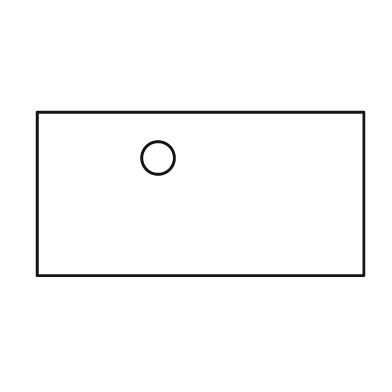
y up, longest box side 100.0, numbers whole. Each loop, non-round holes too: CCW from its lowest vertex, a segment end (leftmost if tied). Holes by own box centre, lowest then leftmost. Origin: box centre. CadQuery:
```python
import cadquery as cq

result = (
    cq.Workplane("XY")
    .moveTo(-50.0, -25.0)
    .lineTo(50.0, -25.0)
    .lineTo(50.0, 25.0)
    .lineTo(-50.0, 25.0)
    .close()
    .moveTo(-13.0, 11.0)
    .circle(5.0)
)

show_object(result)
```